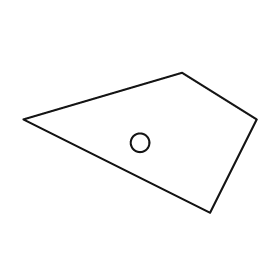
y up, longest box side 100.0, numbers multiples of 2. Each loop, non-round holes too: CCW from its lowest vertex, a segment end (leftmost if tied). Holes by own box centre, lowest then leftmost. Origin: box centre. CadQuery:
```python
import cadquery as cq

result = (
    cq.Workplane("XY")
    .moveTo(30.0, -30.0)
    .lineTo(50.0, 10.0)
    .lineTo(18.0, 30.0)
    .lineTo(-50.0, 10.0)
    .close()
    .moveTo(0.0, 0.0)
    .circle(4.0)
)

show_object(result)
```